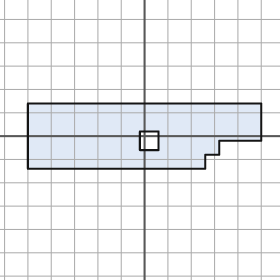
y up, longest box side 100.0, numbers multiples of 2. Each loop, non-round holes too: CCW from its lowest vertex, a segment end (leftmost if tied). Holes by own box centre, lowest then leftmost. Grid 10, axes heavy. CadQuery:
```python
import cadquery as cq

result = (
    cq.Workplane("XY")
    .moveTo(-50.0, -14.0)
    .lineTo(26.0, -14.0)
    .lineTo(26.0, -8.0)
    .lineTo(32.0, -8.0)
    .lineTo(32.0, -2.0)
    .lineTo(50.0, -2.0)
    .lineTo(50.0, 14.0)
    .lineTo(-50.0, 14.0)
    .close()
    .moveTo(-2.0, -6.0)
    .lineTo(6.0, -6.0)
    .lineTo(6.0, 2.0)
    .lineTo(-2.0, 2.0)
    .close()
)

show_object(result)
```